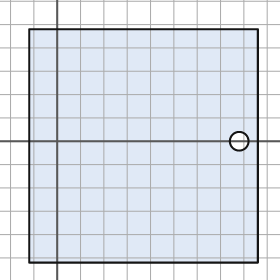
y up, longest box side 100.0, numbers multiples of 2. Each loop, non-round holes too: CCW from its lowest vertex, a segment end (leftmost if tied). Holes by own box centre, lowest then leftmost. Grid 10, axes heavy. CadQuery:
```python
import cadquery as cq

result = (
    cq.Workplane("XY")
    .moveTo(-12.0, -52.0)
    .lineTo(86.0, -52.0)
    .lineTo(86.0, 48.0)
    .lineTo(-12.0, 48.0)
    .close()
    .moveTo(78.0, 0.0)
    .circle(4.0)
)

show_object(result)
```